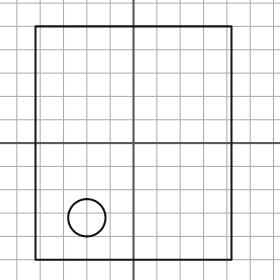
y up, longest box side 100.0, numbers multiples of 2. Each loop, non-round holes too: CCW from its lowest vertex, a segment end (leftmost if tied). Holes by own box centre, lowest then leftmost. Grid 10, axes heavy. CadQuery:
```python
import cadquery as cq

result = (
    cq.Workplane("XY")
    .moveTo(-42.0, -50.0)
    .lineTo(42.0, -50.0)
    .lineTo(42.0, 50.0)
    .lineTo(-42.0, 50.0)
    .close()
    .moveTo(-20.0, -32.0)
    .circle(8.0)
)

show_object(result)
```